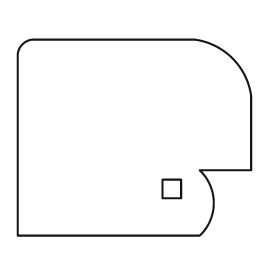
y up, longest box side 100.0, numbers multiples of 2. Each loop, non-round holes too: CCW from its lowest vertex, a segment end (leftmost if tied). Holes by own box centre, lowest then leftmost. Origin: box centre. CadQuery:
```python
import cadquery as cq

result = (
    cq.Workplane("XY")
    .moveTo(-50.0, -42.0)
    .lineTo(28.0, -42.0)
    .threePointArc((34.0, -28.0), (28.0, -14.0))
    .lineTo(50.0, -14.0)
    .lineTo(50.0, 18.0)
    .threePointArc((42.0, 34.0), (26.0, 42.0))
    .lineTo(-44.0, 42.0)
    .threePointArc((-48.0, 40.0), (-50.0, 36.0))
    .close()
    .moveTo(12.0, -26.0)
    .lineTo(20.0, -26.0)
    .lineTo(20.0, -18.0)
    .lineTo(12.0, -18.0)
    .close()
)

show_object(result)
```